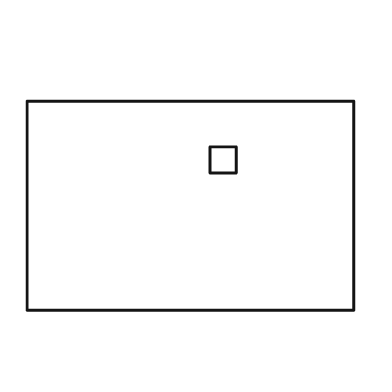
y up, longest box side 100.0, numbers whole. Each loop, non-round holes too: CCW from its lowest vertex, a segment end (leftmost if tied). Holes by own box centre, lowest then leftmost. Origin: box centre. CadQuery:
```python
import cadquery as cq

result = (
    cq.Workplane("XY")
    .moveTo(-50.0, -32.0)
    .lineTo(50.0, -32.0)
    .lineTo(50.0, 32.0)
    .lineTo(-50.0, 32.0)
    .close()
    .moveTo(6.0, 10.0)
    .lineTo(14.0, 10.0)
    .lineTo(14.0, 18.0)
    .lineTo(6.0, 18.0)
    .close()
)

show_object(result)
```